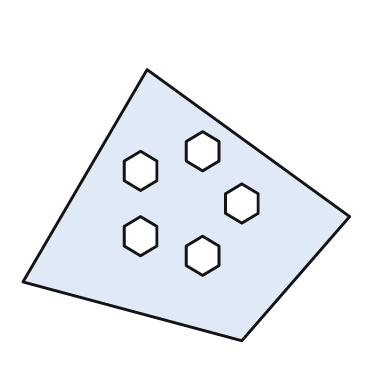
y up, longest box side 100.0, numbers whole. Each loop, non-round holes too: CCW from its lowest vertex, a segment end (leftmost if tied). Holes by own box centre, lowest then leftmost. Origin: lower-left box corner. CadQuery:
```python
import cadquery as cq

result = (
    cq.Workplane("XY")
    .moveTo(67.0, 0.0)
    .lineTo(100.0, 38.0)
    .lineTo(38.0, 83.0)
    .lineTo(0.0, 18.0)
    .close()
    .moveTo(55.0, 20.0)
    .lineTo(60.0, 23.0)
    .lineTo(60.0, 29.0)
    .lineTo(55.0, 32.0)
    .lineTo(50.0, 29.0)
    .lineTo(50.0, 23.0)
    .close()
    .moveTo(36.0, 26.0)
    .lineTo(41.0, 29.0)
    .lineTo(41.0, 35.0)
    .lineTo(36.0, 38.0)
    .lineTo(31.0, 35.0)
    .lineTo(31.0, 29.0)
    .close()
    .moveTo(67.0, 36.0)
    .lineTo(72.0, 39.0)
    .lineTo(72.0, 45.0)
    .lineTo(67.0, 48.0)
    .lineTo(62.0, 45.0)
    .lineTo(62.0, 39.0)
    .close()
    .moveTo(36.0, 46.0)
    .lineTo(41.0, 49.0)
    .lineTo(41.0, 55.0)
    .lineTo(36.0, 58.0)
    .lineTo(31.0, 55.0)
    .lineTo(31.0, 49.0)
    .close()
    .moveTo(55.0, 52.0)
    .lineTo(60.0, 55.0)
    .lineTo(60.0, 61.0)
    .lineTo(55.0, 64.0)
    .lineTo(50.0, 61.0)
    .lineTo(50.0, 55.0)
    .close()
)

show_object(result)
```